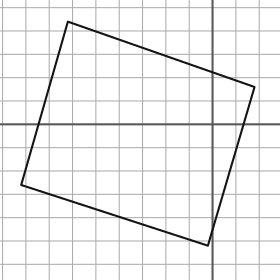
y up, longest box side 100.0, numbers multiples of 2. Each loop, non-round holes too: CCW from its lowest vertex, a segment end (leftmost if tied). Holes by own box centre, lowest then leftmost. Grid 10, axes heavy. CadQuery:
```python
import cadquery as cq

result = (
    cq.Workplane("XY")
    .moveTo(-2.0, -52.0)
    .lineTo(18.0, 16.0)
    .lineTo(-62.0, 44.0)
    .lineTo(-82.0, -26.0)
    .close()
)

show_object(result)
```